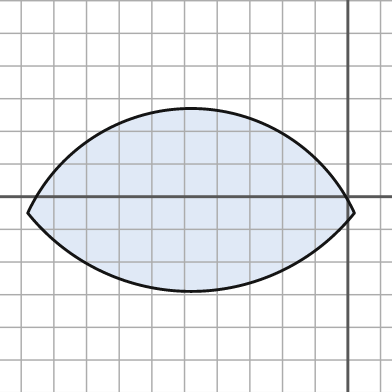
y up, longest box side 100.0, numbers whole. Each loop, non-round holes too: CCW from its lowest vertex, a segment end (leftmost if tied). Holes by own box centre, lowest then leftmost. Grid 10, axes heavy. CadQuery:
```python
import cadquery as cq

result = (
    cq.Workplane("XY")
    .moveTo(-98.0, -5.0)
    .threePointArc((-48.0, -29.0), (2.0, -5.0))
    .threePointArc((-48.0, 27.0), (-98.0, -5.0))
    .close()
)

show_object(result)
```